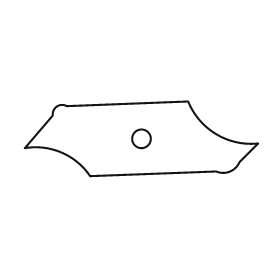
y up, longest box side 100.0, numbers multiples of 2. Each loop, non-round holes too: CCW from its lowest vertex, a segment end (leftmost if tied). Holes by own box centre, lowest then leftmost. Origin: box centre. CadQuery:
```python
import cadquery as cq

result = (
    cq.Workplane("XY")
    .moveTo(-22.0, -16.0)
    .lineTo(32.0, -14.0)
    .threePointArc((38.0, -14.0), (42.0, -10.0))
    .lineTo(50.0, -2.0)
    .threePointArc((32.0, 2.0), (20.0, 16.0))
    .lineTo(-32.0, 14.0)
    .threePointArc((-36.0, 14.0), (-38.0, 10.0))
    .lineTo(-50.0, -4.0)
    .threePointArc((-34.0, -6.0), (-22.0, -16.0))
    .close()
    .moveTo(0.0, 0.0)
    .circle(4.0)
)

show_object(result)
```